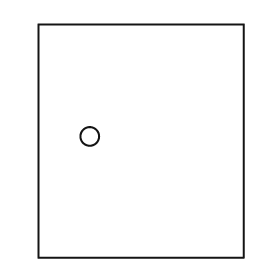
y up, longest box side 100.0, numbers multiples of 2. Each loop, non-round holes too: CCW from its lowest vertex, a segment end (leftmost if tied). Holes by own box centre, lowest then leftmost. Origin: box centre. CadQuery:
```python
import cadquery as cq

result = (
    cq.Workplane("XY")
    .moveTo(-44.0, -50.0)
    .lineTo(44.0, -50.0)
    .lineTo(44.0, 50.0)
    .lineTo(-44.0, 50.0)
    .close()
    .moveTo(-22.0, 2.0)
    .circle(4.0)
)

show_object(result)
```